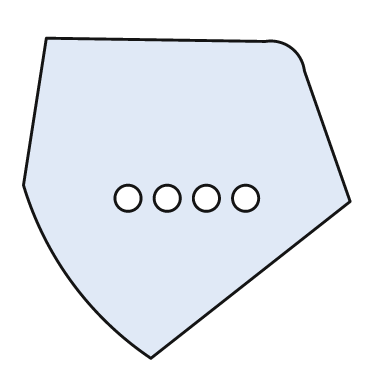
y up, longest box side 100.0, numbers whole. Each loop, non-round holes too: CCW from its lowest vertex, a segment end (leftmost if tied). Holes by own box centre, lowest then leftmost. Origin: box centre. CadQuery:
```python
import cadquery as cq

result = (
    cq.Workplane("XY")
    .moveTo(-11.0, -49.0)
    .lineTo(50.0, -1.0)
    .lineTo(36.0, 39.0)
    .threePointArc((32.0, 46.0), (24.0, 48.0))
    .lineTo(-43.0, 49.0)
    .lineTo(-50.0, 4.0)
    .threePointArc((-35.0, -26.0), (-11.0, -49.0))
    .close()
    .moveTo(-18.0, 0.0)
    .circle(4.0)
    .moveTo(-6.0, 0.0)
    .circle(4.0)
    .moveTo(6.0, 0.0)
    .circle(4.0)
    .moveTo(18.0, 0.0)
    .circle(4.0)
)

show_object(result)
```